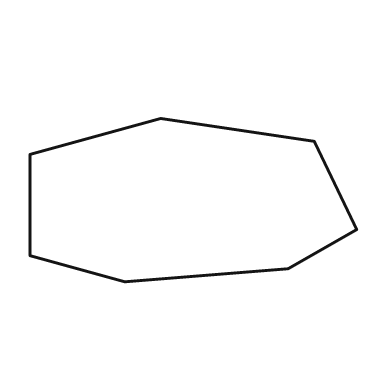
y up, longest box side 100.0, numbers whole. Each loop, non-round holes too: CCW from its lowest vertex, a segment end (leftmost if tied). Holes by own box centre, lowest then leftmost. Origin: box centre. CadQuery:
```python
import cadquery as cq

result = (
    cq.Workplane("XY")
    .moveTo(-21.0, -25.0)
    .lineTo(29.0, -21.0)
    .lineTo(50.0, -9.0)
    .lineTo(37.0, 18.0)
    .lineTo(-10.0, 25.0)
    .lineTo(-50.0, 14.0)
    .lineTo(-50.0, -17.0)
    .close()
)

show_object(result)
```